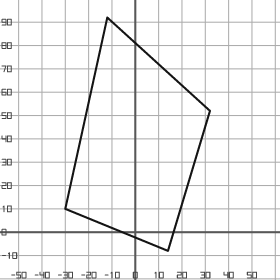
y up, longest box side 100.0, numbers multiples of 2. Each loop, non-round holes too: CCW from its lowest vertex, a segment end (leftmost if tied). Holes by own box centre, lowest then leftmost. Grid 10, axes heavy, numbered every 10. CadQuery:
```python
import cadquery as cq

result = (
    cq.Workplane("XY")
    .moveTo(14.0, -8.0)
    .lineTo(32.0, 52.0)
    .lineTo(-12.0, 92.0)
    .lineTo(-30.0, 10.0)
    .close()
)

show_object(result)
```